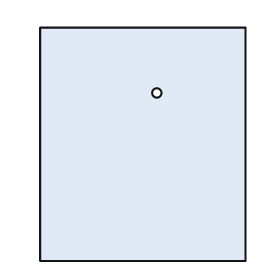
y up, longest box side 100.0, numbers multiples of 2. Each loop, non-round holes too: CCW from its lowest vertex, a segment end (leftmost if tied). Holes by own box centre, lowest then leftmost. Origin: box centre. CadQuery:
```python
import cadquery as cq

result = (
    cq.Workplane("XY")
    .moveTo(-44.0, -50.0)
    .lineTo(44.0, -50.0)
    .lineTo(44.0, 50.0)
    .lineTo(-44.0, 50.0)
    .close()
    .moveTo(6.0, 22.0)
    .circle(2.0)
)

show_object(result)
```